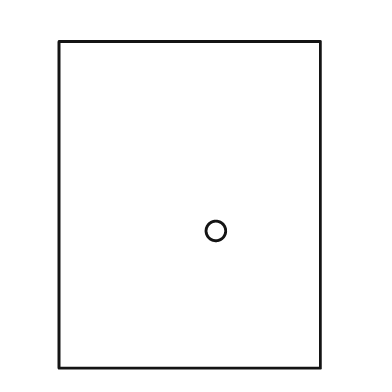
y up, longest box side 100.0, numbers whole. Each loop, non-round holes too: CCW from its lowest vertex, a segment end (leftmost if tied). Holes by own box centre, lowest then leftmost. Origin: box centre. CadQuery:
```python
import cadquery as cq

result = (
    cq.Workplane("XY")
    .moveTo(-40.0, -50.0)
    .lineTo(40.0, -50.0)
    .lineTo(40.0, 50.0)
    .lineTo(-40.0, 50.0)
    .close()
    .moveTo(8.0, -8.0)
    .circle(3.0)
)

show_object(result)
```